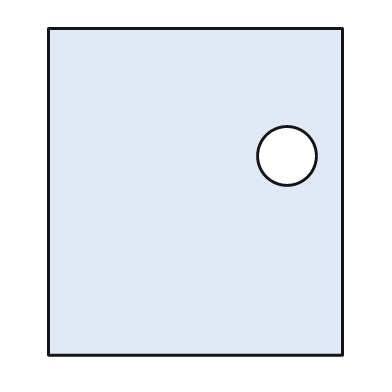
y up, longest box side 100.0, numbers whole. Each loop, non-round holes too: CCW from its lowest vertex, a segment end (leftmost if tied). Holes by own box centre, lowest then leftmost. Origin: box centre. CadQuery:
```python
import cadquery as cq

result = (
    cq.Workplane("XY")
    .moveTo(-45.0, -50.0)
    .lineTo(45.0, -50.0)
    .lineTo(45.0, 50.0)
    .lineTo(-45.0, 50.0)
    .close()
    .moveTo(28.0, 11.0)
    .circle(9.0)
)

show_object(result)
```